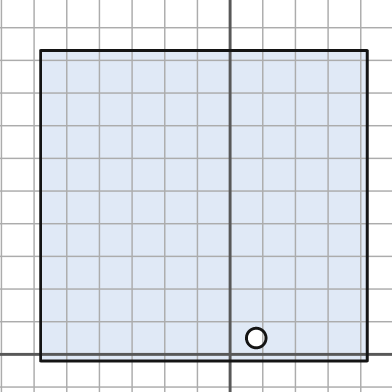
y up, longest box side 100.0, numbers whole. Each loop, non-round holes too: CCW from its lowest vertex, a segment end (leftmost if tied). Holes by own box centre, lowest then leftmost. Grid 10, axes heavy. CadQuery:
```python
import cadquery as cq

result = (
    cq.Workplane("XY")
    .moveTo(-58.0, -2.0)
    .lineTo(42.0, -2.0)
    .lineTo(42.0, 93.0)
    .lineTo(-58.0, 93.0)
    .close()
    .moveTo(8.0, 5.0)
    .circle(3.0)
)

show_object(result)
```